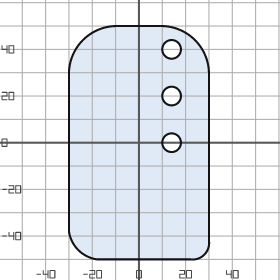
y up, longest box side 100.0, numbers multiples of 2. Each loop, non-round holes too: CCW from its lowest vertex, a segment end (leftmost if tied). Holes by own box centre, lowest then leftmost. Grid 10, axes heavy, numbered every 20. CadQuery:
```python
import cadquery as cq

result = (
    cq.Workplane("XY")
    .moveTo(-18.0, -50.0)
    .lineTo(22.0, -50.0)
    .threePointArc((28.0, -48.0), (30.0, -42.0))
    .lineTo(30.0, 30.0)
    .threePointArc((24.0, 44.0), (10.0, 50.0))
    .lineTo(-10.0, 50.0)
    .threePointArc((-24.0, 44.0), (-30.0, 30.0))
    .lineTo(-30.0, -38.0)
    .threePointArc((-26.0, -46.0), (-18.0, -50.0))
    .close()
    .moveTo(14.0, 0.0)
    .circle(4.0)
    .moveTo(14.0, 20.0)
    .circle(4.0)
    .moveTo(14.0, 40.0)
    .circle(4.0)
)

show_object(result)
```